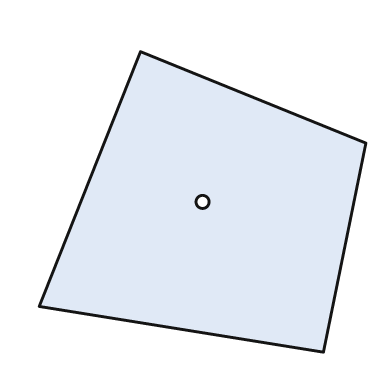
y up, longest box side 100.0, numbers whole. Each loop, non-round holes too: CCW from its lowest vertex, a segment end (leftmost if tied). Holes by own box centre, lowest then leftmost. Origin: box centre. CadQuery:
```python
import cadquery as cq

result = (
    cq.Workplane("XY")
    .moveTo(37.0, -46.0)
    .lineTo(50.0, 18.0)
    .lineTo(-19.0, 46.0)
    .lineTo(-50.0, -32.0)
    .close()
    .moveTo(0.0, 0.0)
    .circle(2.0)
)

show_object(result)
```